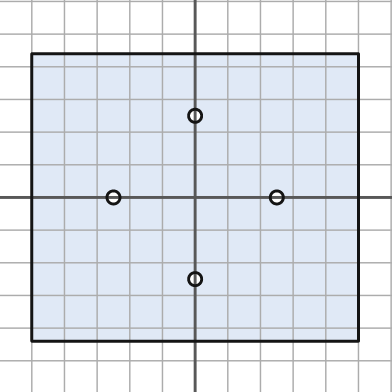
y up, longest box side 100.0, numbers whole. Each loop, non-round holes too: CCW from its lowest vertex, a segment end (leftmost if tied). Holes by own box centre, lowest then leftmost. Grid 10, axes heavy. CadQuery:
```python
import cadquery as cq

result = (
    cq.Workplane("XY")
    .moveTo(-50.0, -44.0)
    .lineTo(50.0, -44.0)
    .lineTo(50.0, 44.0)
    .lineTo(-50.0, 44.0)
    .close()
    .moveTo(0.0, -25.0)
    .circle(2.0)
    .moveTo(-25.0, 0.0)
    .circle(2.0)
    .moveTo(25.0, 0.0)
    .circle(2.0)
    .moveTo(0.0, 25.0)
    .circle(2.0)
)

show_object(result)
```